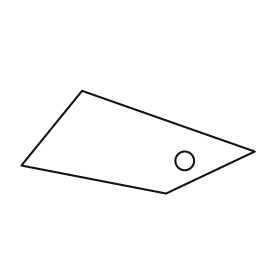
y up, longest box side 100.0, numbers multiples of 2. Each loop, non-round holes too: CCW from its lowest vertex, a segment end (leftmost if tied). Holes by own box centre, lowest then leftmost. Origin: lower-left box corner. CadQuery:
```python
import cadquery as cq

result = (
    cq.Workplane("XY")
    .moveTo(62.0, 0.0)
    .lineTo(100.0, 18.0)
    .lineTo(26.0, 44.0)
    .lineTo(0.0, 12.0)
    .close()
    .moveTo(70.0, 14.0)
    .circle(4.0)
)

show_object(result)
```